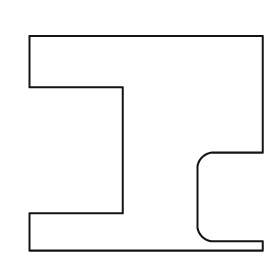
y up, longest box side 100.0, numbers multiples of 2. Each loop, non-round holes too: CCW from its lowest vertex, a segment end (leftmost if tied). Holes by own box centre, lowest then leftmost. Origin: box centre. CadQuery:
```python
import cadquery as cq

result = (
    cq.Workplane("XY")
    .moveTo(-50.0, -46.0)
    .lineTo(50.0, -46.0)
    .lineTo(50.0, -42.0)
    .lineTo(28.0, -42.0)
    .threePointArc((24.0, -40.0), (22.0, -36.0))
    .lineTo(22.0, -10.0)
    .threePointArc((24.0, -6.0), (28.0, -4.0))
    .lineTo(50.0, -4.0)
    .lineTo(50.0, 46.0)
    .lineTo(-50.0, 46.0)
    .lineTo(-50.0, 24.0)
    .lineTo(-10.0, 24.0)
    .lineTo(-10.0, -30.0)
    .lineTo(-50.0, -30.0)
    .close()
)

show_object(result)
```